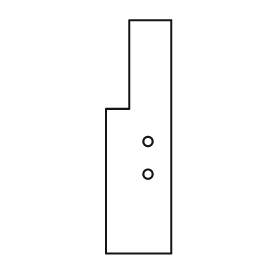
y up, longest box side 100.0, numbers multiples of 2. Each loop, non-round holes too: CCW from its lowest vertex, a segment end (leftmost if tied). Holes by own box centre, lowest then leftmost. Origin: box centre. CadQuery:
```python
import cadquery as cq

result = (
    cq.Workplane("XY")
    .moveTo(-14.0, -50.0)
    .lineTo(14.0, -50.0)
    .lineTo(14.0, 50.0)
    .lineTo(-4.0, 50.0)
    .lineTo(-4.0, 12.0)
    .lineTo(-14.0, 12.0)
    .close()
    .moveTo(4.0, -16.0)
    .circle(2.0)
    .moveTo(4.0, -2.0)
    .circle(2.0)
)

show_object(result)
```